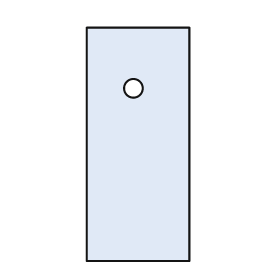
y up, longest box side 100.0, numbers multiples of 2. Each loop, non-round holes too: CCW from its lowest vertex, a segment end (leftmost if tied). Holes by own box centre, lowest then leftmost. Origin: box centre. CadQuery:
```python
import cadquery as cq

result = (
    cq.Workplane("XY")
    .moveTo(-22.0, -50.0)
    .lineTo(22.0, -50.0)
    .lineTo(22.0, 50.0)
    .lineTo(-22.0, 50.0)
    .close()
    .moveTo(-2.0, 24.0)
    .circle(4.0)
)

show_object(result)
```